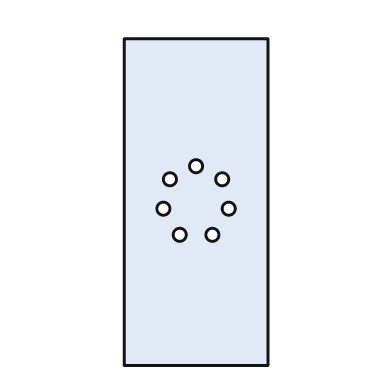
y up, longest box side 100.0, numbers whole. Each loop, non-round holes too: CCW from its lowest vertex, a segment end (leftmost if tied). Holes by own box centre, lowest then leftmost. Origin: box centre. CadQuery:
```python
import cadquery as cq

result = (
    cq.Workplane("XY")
    .moveTo(-22.0, -50.0)
    .lineTo(22.0, -50.0)
    .lineTo(22.0, 50.0)
    .lineTo(-22.0, 50.0)
    .close()
    .moveTo(-5.0, -10.0)
    .circle(2.0)
    .moveTo(5.0, -10.0)
    .circle(2.0)
    .moveTo(-10.0, -2.0)
    .circle(2.0)
    .moveTo(10.0, -2.0)
    .circle(2.0)
    .moveTo(-8.0, 7.0)
    .circle(2.0)
    .moveTo(8.0, 7.0)
    .circle(2.0)
    .moveTo(0.0, 11.0)
    .circle(2.0)
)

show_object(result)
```